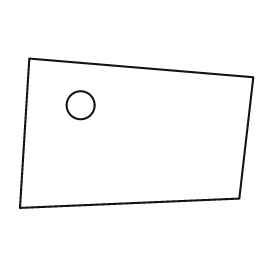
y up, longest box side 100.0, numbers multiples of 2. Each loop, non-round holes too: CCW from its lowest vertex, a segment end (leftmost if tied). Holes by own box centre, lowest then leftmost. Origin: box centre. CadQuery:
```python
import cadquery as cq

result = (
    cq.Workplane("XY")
    .moveTo(-50.0, -32.0)
    .lineTo(44.0, -28.0)
    .lineTo(50.0, 24.0)
    .lineTo(-46.0, 32.0)
    .close()
    .moveTo(-24.0, 12.0)
    .circle(6.0)
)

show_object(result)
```